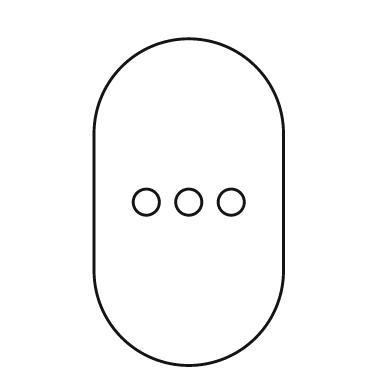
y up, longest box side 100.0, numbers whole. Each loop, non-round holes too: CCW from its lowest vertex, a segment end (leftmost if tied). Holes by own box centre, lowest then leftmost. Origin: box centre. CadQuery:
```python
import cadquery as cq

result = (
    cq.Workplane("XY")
    .moveTo(-29.0, -21.0)
    .threePointArc((0.0, -50.0), (29.0, -21.0))
    .lineTo(29.0, 21.0)
    .threePointArc((0.0, 50.0), (-29.0, 21.0))
    .close()
    .moveTo(-13.0, 0.0)
    .circle(4.0)
    .moveTo(0.0, 0.0)
    .circle(4.0)
    .moveTo(13.0, 0.0)
    .circle(4.0)
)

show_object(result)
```